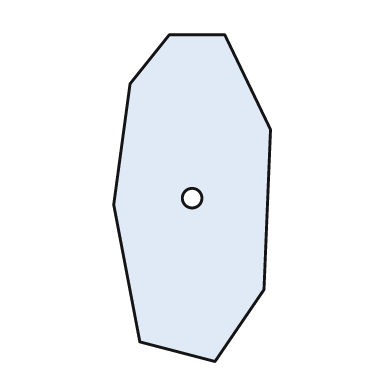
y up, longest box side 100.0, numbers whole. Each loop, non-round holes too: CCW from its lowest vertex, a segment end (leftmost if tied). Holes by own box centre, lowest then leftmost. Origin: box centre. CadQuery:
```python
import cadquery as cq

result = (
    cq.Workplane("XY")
    .moveTo(7.0, -50.0)
    .lineTo(22.0, -28.0)
    .lineTo(24.0, 21.0)
    .lineTo(10.0, 50.0)
    .lineTo(-7.0, 50.0)
    .lineTo(-19.0, 35.0)
    .lineTo(-24.0, -2.0)
    .lineTo(-16.0, -44.0)
    .close()
    .moveTo(0.0, 0.0)
    .circle(3.0)
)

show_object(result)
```